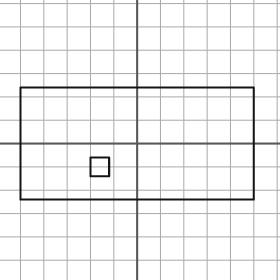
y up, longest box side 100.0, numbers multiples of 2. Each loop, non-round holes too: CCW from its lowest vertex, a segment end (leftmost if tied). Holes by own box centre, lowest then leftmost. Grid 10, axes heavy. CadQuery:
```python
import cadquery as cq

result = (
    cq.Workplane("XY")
    .moveTo(-50.0, -24.0)
    .lineTo(50.0, -24.0)
    .lineTo(50.0, 24.0)
    .lineTo(-50.0, 24.0)
    .close()
    .moveTo(-20.0, -14.0)
    .lineTo(-12.0, -14.0)
    .lineTo(-12.0, -6.0)
    .lineTo(-20.0, -6.0)
    .close()
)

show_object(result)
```